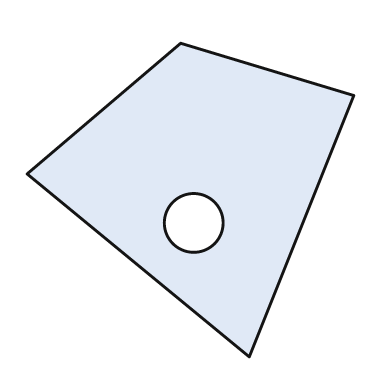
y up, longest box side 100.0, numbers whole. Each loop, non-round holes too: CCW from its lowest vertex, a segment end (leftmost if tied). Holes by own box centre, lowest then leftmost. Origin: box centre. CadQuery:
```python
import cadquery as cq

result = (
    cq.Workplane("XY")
    .moveTo(18.0, -48.0)
    .lineTo(50.0, 32.0)
    .lineTo(-3.0, 48.0)
    .lineTo(-50.0, 8.0)
    .close()
    .moveTo(1.0, -7.0)
    .circle(9.0)
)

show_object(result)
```